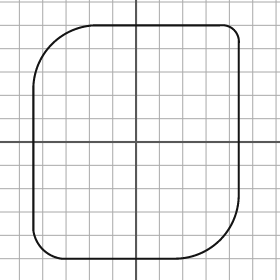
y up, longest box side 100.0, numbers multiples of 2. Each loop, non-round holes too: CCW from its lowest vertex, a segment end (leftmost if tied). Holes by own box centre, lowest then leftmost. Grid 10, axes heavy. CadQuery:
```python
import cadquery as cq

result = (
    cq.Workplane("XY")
    .moveTo(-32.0, -50.0)
    .lineTo(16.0, -50.0)
    .threePointArc((36.0, -42.0), (44.0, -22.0))
    .lineTo(44.0, 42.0)
    .threePointArc((42.0, 48.0), (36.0, 50.0))
    .lineTo(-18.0, 50.0)
    .threePointArc((-36.0, 42.0), (-44.0, 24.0))
    .lineTo(-44.0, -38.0)
    .threePointArc((-40.0, -46.0), (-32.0, -50.0))
    .close()
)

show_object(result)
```